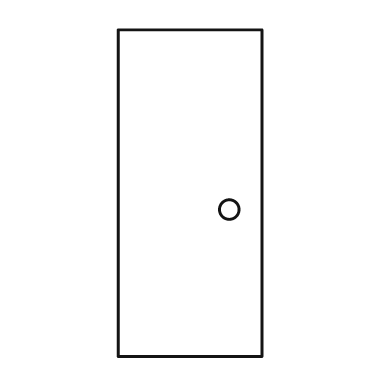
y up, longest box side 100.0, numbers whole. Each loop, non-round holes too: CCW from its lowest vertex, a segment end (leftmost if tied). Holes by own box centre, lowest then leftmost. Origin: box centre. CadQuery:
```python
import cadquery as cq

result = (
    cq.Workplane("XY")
    .moveTo(-22.0, -50.0)
    .lineTo(22.0, -50.0)
    .lineTo(22.0, 50.0)
    .lineTo(-22.0, 50.0)
    .close()
    .moveTo(12.0, -5.0)
    .circle(3.0)
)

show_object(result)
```